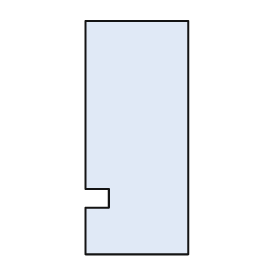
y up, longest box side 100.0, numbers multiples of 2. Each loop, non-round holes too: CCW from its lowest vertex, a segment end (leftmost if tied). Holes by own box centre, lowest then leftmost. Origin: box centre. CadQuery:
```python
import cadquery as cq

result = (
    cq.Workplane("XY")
    .moveTo(-22.0, -50.0)
    .lineTo(22.0, -50.0)
    .lineTo(22.0, 50.0)
    .lineTo(-22.0, 50.0)
    .lineTo(-22.0, -22.0)
    .lineTo(-12.0, -22.0)
    .lineTo(-12.0, -30.0)
    .lineTo(-22.0, -30.0)
    .close()
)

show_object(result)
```